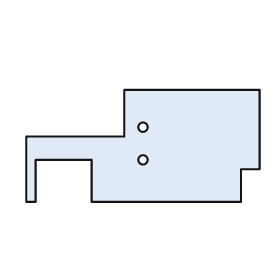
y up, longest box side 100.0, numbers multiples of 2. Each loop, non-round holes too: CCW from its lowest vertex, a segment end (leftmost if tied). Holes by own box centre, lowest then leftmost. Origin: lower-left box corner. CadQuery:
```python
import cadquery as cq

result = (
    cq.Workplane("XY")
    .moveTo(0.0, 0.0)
    .lineTo(4.0, 0.0)
    .lineTo(4.0, 18.0)
    .lineTo(28.0, 18.0)
    .lineTo(28.0, 0.0)
    .lineTo(92.0, 0.0)
    .lineTo(92.0, 14.0)
    .lineTo(100.0, 14.0)
    .lineTo(100.0, 48.0)
    .lineTo(42.0, 48.0)
    .lineTo(42.0, 28.0)
    .lineTo(0.0, 28.0)
    .close()
    .moveTo(50.0, 18.0)
    .circle(2.0)
    .moveTo(50.0, 32.0)
    .circle(2.0)
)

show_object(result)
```